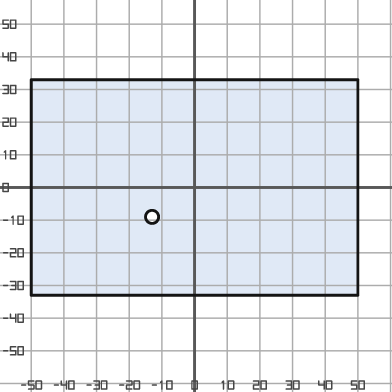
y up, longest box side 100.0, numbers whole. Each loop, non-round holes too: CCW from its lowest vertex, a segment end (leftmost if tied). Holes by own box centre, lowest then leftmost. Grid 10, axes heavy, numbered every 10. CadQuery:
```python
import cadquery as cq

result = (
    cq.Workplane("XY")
    .moveTo(-50.0, -33.0)
    .lineTo(50.0, -33.0)
    .lineTo(50.0, 33.0)
    .lineTo(-50.0, 33.0)
    .close()
    .moveTo(-13.0, -9.0)
    .circle(2.0)
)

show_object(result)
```